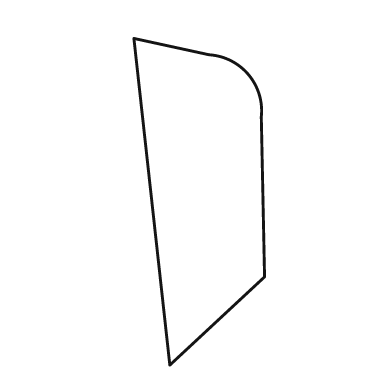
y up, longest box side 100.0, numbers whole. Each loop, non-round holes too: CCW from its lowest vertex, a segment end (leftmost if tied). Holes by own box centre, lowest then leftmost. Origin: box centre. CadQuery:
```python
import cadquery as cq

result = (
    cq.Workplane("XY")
    .moveTo(-9.0, -50.0)
    .lineTo(20.0, -23.0)
    .lineTo(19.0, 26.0)
    .threePointArc((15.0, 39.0), (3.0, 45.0))
    .lineTo(-20.0, 50.0)
    .close()
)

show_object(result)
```